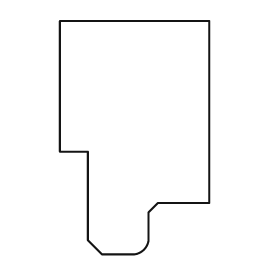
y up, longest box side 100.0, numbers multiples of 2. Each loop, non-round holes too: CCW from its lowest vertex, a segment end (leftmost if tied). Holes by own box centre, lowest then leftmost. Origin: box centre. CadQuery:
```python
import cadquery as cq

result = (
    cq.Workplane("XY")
    .moveTo(-14.0, -50.0)
    .lineTo(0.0, -50.0)
    .threePointArc((4.0, -48.0), (6.0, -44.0))
    .lineTo(6.0, -32.0)
    .lineTo(10.0, -28.0)
    .lineTo(32.0, -28.0)
    .lineTo(32.0, 50.0)
    .lineTo(-32.0, 50.0)
    .lineTo(-32.0, -6.0)
    .lineTo(-20.0, -6.0)
    .lineTo(-20.0, -44.0)
    .close()
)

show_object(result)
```